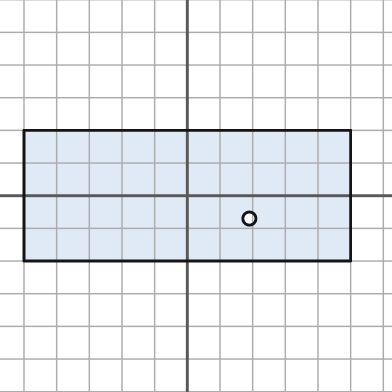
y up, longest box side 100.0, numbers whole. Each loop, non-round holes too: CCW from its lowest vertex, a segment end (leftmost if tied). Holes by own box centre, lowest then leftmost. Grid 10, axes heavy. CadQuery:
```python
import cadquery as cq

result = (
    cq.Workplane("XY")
    .moveTo(-50.0, -20.0)
    .lineTo(50.0, -20.0)
    .lineTo(50.0, 20.0)
    .lineTo(-50.0, 20.0)
    .close()
    .moveTo(19.0, -7.0)
    .circle(2.0)
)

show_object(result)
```